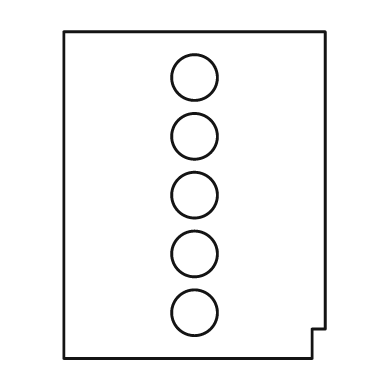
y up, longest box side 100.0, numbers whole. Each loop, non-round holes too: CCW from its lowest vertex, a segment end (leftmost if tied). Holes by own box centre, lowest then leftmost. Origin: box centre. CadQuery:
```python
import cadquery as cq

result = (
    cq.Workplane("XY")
    .moveTo(-40.0, -50.0)
    .lineTo(36.0, -50.0)
    .lineTo(36.0, -41.0)
    .lineTo(40.0, -41.0)
    .lineTo(40.0, 50.0)
    .lineTo(-40.0, 50.0)
    .close()
    .moveTo(0.0, -36.0)
    .circle(7.0)
    .moveTo(0.0, -18.0)
    .circle(7.0)
    .moveTo(0.0, 0.0)
    .circle(7.0)
    .moveTo(0.0, 18.0)
    .circle(7.0)
    .moveTo(0.0, 36.0)
    .circle(7.0)
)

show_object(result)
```